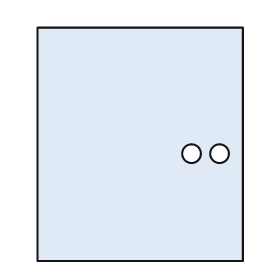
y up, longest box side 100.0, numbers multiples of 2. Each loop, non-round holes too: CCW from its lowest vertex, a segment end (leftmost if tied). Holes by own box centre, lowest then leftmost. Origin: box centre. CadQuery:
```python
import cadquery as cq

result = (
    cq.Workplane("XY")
    .moveTo(-44.0, -50.0)
    .lineTo(44.0, -50.0)
    .lineTo(44.0, 50.0)
    .lineTo(-44.0, 50.0)
    .close()
    .moveTo(22.0, -4.0)
    .circle(4.0)
    .moveTo(34.0, -4.0)
    .circle(4.0)
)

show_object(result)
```